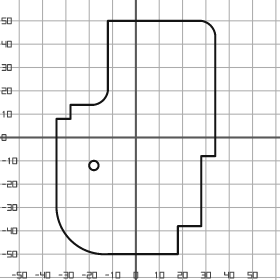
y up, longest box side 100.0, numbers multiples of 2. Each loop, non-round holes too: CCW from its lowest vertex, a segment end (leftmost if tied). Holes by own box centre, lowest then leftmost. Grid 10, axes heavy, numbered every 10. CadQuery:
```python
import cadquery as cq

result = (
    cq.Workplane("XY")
    .moveTo(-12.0, -50.0)
    .lineTo(18.0, -50.0)
    .lineTo(18.0, -38.0)
    .lineTo(28.0, -38.0)
    .lineTo(28.0, -8.0)
    .lineTo(34.0, -8.0)
    .lineTo(34.0, 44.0)
    .threePointArc((32.0, 48.0), (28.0, 50.0))
    .lineTo(-12.0, 50.0)
    .lineTo(-12.0, 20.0)
    .threePointArc((-14.0, 16.0), (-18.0, 14.0))
    .lineTo(-28.0, 14.0)
    .lineTo(-28.0, 8.0)
    .lineTo(-34.0, 8.0)
    .lineTo(-34.0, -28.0)
    .threePointArc((-28.0, -44.0), (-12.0, -50.0))
    .close()
    .moveTo(-18.0, -12.0)
    .circle(2.0)
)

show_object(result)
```